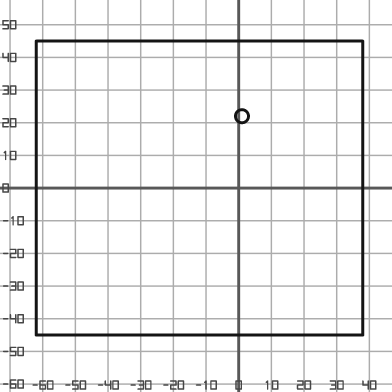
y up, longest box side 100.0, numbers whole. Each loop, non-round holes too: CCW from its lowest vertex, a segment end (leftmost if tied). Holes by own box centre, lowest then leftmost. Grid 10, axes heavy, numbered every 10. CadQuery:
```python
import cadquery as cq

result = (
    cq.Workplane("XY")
    .moveTo(-62.0, -45.0)
    .lineTo(38.0, -45.0)
    .lineTo(38.0, 45.0)
    .lineTo(-62.0, 45.0)
    .close()
    .moveTo(1.0, 22.0)
    .circle(2.0)
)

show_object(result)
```